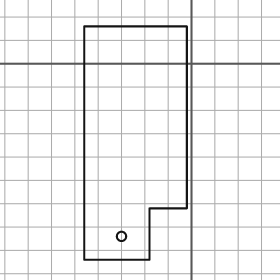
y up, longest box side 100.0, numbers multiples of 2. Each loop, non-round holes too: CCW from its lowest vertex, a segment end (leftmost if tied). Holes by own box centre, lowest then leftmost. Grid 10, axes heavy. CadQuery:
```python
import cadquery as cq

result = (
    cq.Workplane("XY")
    .moveTo(-46.0, -84.0)
    .lineTo(-18.0, -84.0)
    .lineTo(-18.0, -62.0)
    .lineTo(-2.0, -62.0)
    .lineTo(-2.0, 16.0)
    .lineTo(-46.0, 16.0)
    .close()
    .moveTo(-30.0, -74.0)
    .circle(2.0)
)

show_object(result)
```